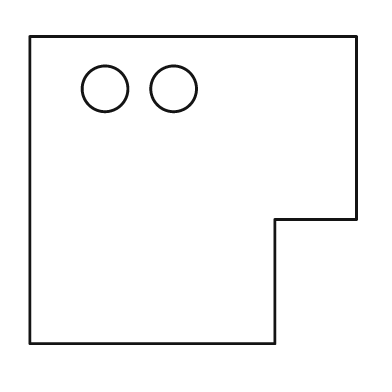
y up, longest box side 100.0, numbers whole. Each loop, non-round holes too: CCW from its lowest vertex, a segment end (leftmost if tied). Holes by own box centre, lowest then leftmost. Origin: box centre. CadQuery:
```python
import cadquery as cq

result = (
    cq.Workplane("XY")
    .moveTo(-50.0, -47.0)
    .lineTo(25.0, -47.0)
    .lineTo(25.0, -9.0)
    .lineTo(50.0, -9.0)
    .lineTo(50.0, 47.0)
    .lineTo(-50.0, 47.0)
    .close()
    .moveTo(-27.0, 31.0)
    .circle(7.0)
    .moveTo(-6.0, 31.0)
    .circle(7.0)
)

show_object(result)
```